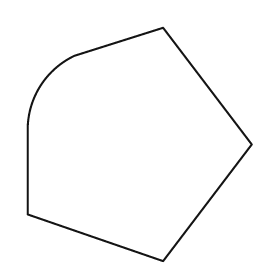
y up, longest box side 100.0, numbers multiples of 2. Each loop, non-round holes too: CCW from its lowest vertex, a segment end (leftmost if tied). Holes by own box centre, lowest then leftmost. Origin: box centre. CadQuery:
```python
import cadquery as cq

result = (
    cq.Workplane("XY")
    .moveTo(10.0, -50.0)
    .lineTo(48.0, 0.0)
    .lineTo(10.0, 50.0)
    .lineTo(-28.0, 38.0)
    .threePointArc((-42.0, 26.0), (-48.0, 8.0))
    .lineTo(-48.0, -30.0)
    .close()
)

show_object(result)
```